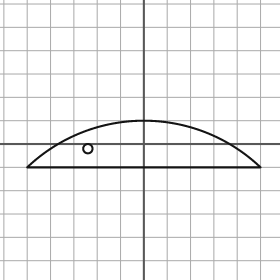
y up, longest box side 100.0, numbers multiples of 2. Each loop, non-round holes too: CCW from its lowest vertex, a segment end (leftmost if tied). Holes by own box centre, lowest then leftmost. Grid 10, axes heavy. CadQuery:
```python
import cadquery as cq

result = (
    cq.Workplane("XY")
    .moveTo(-50.0, -10.0)
    .lineTo(50.0, -10.0)
    .threePointArc((0.0, 10.0), (-50.0, -10.0))
    .close()
    .moveTo(-24.0, -2.0)
    .circle(2.0)
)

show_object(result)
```